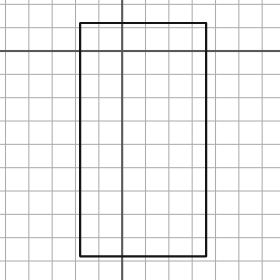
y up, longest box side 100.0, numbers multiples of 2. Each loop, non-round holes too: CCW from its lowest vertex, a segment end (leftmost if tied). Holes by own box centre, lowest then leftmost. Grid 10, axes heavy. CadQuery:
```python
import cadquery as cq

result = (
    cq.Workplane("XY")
    .moveTo(-18.0, -88.0)
    .lineTo(36.0, -88.0)
    .lineTo(36.0, 12.0)
    .lineTo(-18.0, 12.0)
    .close()
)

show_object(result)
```